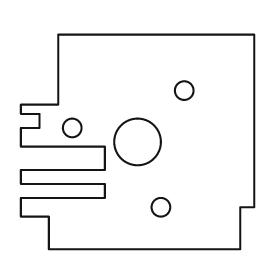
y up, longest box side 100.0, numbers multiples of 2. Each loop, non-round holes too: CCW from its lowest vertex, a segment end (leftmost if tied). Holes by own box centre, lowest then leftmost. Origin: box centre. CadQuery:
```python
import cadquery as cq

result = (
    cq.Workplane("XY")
    .moveTo(-38.0, -46.0)
    .lineTo(44.0, -46.0)
    .lineTo(44.0, -28.0)
    .lineTo(50.0, -28.0)
    .lineTo(50.0, 46.0)
    .lineTo(-34.0, 46.0)
    .lineTo(-34.0, 16.0)
    .lineTo(-50.0, 16.0)
    .lineTo(-50.0, 12.0)
    .lineTo(-42.0, 12.0)
    .lineTo(-42.0, 6.0)
    .lineTo(-50.0, 6.0)
    .lineTo(-50.0, -2.0)
    .lineTo(-14.0, -2.0)
    .lineTo(-14.0, -12.0)
    .lineTo(-50.0, -12.0)
    .lineTo(-50.0, -18.0)
    .lineTo(-14.0, -18.0)
    .lineTo(-14.0, -24.0)
    .lineTo(-50.0, -24.0)
    .lineTo(-50.0, -32.0)
    .lineTo(-38.0, -32.0)
    .close()
    .moveTo(10.0, -28.0)
    .circle(4.0)
    .moveTo(0.0, 0.0)
    .circle(10.0)
    .moveTo(-28.0, 6.0)
    .circle(4.0)
    .moveTo(20.0, 22.0)
    .circle(4.0)
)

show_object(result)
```